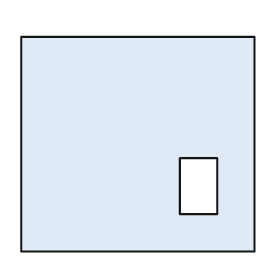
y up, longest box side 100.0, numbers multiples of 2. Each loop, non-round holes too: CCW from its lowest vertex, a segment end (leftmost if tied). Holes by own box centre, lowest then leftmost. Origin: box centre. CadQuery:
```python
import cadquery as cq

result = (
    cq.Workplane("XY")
    .moveTo(-50.0, -46.0)
    .lineTo(50.0, -46.0)
    .lineTo(50.0, 46.0)
    .lineTo(-50.0, 46.0)
    .close()
    .moveTo(18.0, -30.0)
    .lineTo(34.0, -30.0)
    .lineTo(34.0, -6.0)
    .lineTo(18.0, -6.0)
    .close()
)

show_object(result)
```